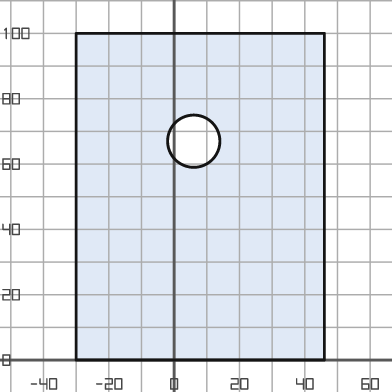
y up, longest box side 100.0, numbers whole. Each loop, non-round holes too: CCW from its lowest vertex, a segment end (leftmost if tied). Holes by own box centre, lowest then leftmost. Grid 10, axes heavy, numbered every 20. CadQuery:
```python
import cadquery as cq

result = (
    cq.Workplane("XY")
    .moveTo(-30.0, 0.0)
    .lineTo(46.0, 0.0)
    .lineTo(46.0, 100.0)
    .lineTo(-30.0, 100.0)
    .close()
    .moveTo(6.0, 67.0)
    .circle(8.0)
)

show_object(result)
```